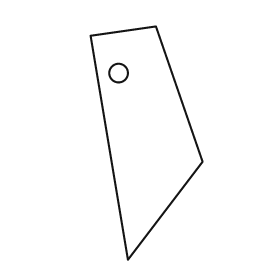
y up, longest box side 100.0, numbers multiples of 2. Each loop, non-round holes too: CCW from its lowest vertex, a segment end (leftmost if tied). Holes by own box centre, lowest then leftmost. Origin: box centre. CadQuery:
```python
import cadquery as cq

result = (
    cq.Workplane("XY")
    .moveTo(-8.0, -50.0)
    .lineTo(24.0, -8.0)
    .lineTo(4.0, 50.0)
    .lineTo(-24.0, 46.0)
    .close()
    .moveTo(-12.0, 30.0)
    .circle(4.0)
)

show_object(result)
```